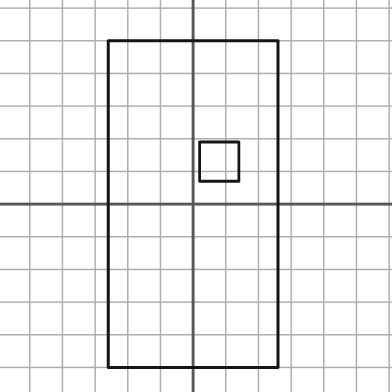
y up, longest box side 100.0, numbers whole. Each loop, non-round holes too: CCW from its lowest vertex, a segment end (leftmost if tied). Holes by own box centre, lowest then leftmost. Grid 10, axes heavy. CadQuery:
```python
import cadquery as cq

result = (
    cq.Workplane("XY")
    .moveTo(-26.0, -50.0)
    .lineTo(26.0, -50.0)
    .lineTo(26.0, 50.0)
    .lineTo(-26.0, 50.0)
    .close()
    .moveTo(2.0, 7.0)
    .lineTo(14.0, 7.0)
    .lineTo(14.0, 19.0)
    .lineTo(2.0, 19.0)
    .close()
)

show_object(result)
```